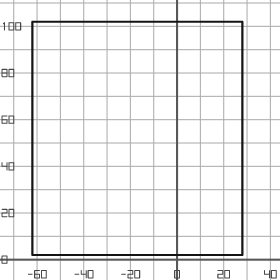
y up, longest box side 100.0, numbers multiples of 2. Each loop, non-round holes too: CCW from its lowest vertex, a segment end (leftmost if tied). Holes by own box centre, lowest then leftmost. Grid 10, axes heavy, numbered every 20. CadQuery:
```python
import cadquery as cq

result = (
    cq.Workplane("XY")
    .moveTo(-62.0, 2.0)
    .lineTo(28.0, 2.0)
    .lineTo(28.0, 102.0)
    .lineTo(-62.0, 102.0)
    .close()
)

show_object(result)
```